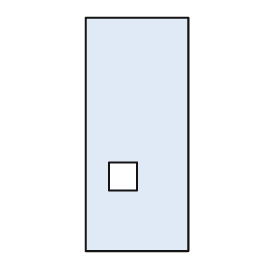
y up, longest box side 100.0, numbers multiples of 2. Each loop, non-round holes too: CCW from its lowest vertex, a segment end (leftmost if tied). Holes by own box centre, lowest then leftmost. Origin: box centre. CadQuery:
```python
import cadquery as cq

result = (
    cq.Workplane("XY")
    .moveTo(-22.0, -50.0)
    .lineTo(22.0, -50.0)
    .lineTo(22.0, 50.0)
    .lineTo(-22.0, 50.0)
    .close()
    .moveTo(-12.0, -24.0)
    .lineTo(0.0, -24.0)
    .lineTo(0.0, -12.0)
    .lineTo(-12.0, -12.0)
    .close()
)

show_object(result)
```